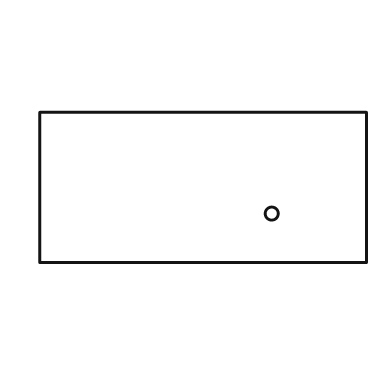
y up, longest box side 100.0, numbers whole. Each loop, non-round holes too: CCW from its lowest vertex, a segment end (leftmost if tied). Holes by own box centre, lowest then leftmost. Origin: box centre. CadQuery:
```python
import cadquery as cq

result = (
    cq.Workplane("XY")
    .moveTo(-50.0, -23.0)
    .lineTo(50.0, -23.0)
    .lineTo(50.0, 23.0)
    .lineTo(-50.0, 23.0)
    .close()
    .moveTo(21.0, -8.0)
    .circle(2.0)
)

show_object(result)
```